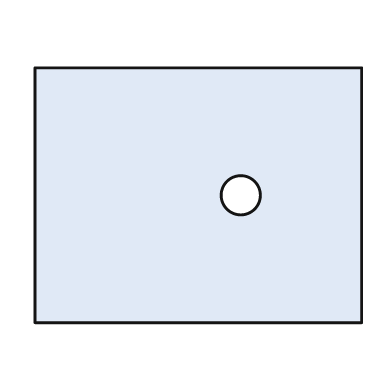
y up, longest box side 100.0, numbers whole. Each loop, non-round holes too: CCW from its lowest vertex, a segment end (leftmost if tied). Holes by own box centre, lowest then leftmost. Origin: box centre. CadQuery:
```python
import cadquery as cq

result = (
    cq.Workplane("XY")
    .moveTo(-50.0, -39.0)
    .lineTo(50.0, -39.0)
    .lineTo(50.0, 39.0)
    .lineTo(-50.0, 39.0)
    .close()
    .moveTo(13.0, 0.0)
    .circle(6.0)
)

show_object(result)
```